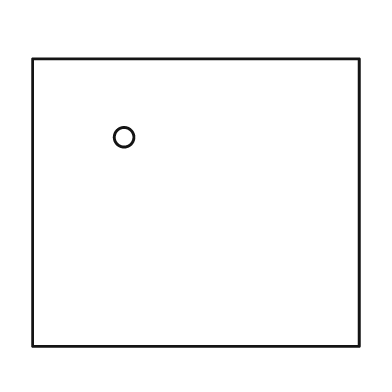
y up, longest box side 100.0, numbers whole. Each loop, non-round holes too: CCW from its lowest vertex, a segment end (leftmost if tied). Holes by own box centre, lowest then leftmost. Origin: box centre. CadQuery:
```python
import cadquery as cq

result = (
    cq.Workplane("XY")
    .moveTo(-50.0, -44.0)
    .lineTo(50.0, -44.0)
    .lineTo(50.0, 44.0)
    .lineTo(-50.0, 44.0)
    .close()
    .moveTo(-22.0, 20.0)
    .circle(3.0)
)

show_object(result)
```